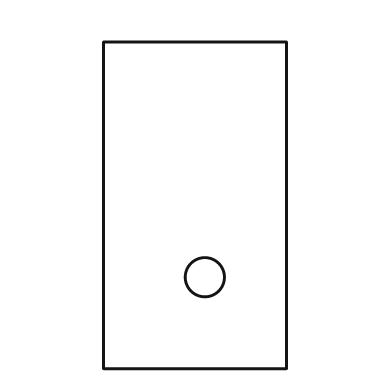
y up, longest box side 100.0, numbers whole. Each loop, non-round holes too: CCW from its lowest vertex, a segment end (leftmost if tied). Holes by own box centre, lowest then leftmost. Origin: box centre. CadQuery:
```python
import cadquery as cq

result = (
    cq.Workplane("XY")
    .moveTo(-28.0, -50.0)
    .lineTo(28.0, -50.0)
    .lineTo(28.0, 50.0)
    .lineTo(-28.0, 50.0)
    .close()
    .moveTo(3.0, -22.0)
    .circle(6.0)
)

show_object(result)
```